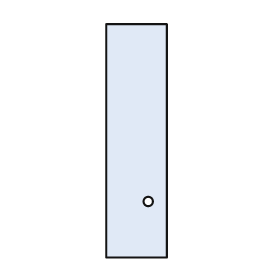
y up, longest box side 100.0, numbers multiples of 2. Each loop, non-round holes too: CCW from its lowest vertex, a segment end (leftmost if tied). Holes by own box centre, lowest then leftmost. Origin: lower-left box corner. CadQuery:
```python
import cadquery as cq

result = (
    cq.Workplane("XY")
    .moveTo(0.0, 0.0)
    .lineTo(26.0, 0.0)
    .lineTo(26.0, 100.0)
    .lineTo(0.0, 100.0)
    .close()
    .moveTo(18.0, 24.0)
    .circle(2.0)
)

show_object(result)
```